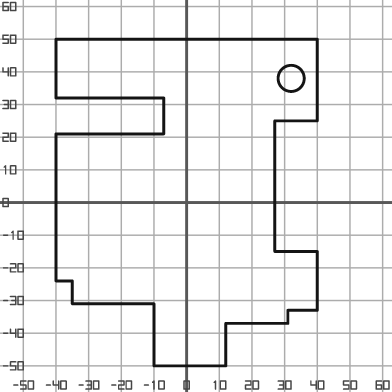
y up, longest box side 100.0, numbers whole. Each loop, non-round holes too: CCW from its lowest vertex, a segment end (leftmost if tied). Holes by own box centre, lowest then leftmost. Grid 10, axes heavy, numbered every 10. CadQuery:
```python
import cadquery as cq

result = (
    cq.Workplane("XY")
    .moveTo(-10.0, -50.0)
    .lineTo(12.0, -50.0)
    .lineTo(12.0, -37.0)
    .lineTo(31.0, -37.0)
    .lineTo(31.0, -33.0)
    .lineTo(40.0, -33.0)
    .lineTo(40.0, -15.0)
    .lineTo(27.0, -15.0)
    .lineTo(27.0, 25.0)
    .lineTo(40.0, 25.0)
    .lineTo(40.0, 50.0)
    .lineTo(-40.0, 50.0)
    .lineTo(-40.0, 32.0)
    .lineTo(-7.0, 32.0)
    .lineTo(-7.0, 21.0)
    .lineTo(-40.0, 21.0)
    .lineTo(-40.0, -24.0)
    .lineTo(-35.0, -24.0)
    .lineTo(-35.0, -31.0)
    .lineTo(-10.0, -31.0)
    .close()
    .moveTo(32.0, 38.0)
    .circle(4.0)
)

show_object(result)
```